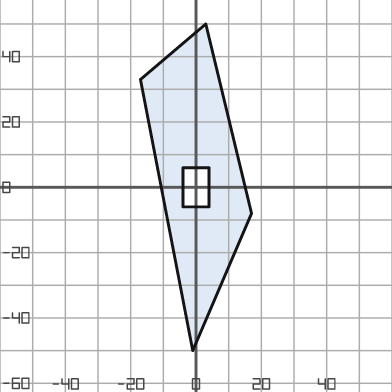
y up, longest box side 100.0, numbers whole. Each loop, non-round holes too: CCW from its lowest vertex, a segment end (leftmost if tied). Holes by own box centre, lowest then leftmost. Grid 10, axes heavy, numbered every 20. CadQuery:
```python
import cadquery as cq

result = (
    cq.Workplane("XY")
    .moveTo(-1.0, -50.0)
    .lineTo(17.0, -8.0)
    .lineTo(3.0, 50.0)
    .lineTo(-17.0, 33.0)
    .close()
    .moveTo(-4.0, -6.0)
    .lineTo(4.0, -6.0)
    .lineTo(4.0, 6.0)
    .lineTo(-4.0, 6.0)
    .close()
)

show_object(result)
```